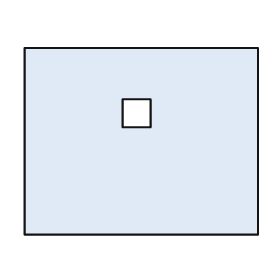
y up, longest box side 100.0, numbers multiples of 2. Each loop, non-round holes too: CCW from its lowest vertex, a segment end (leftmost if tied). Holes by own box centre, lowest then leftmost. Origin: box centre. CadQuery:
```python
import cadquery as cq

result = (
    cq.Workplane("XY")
    .moveTo(-50.0, -40.0)
    .lineTo(50.0, -40.0)
    .lineTo(50.0, 40.0)
    .lineTo(-50.0, 40.0)
    .close()
    .moveTo(-8.0, 6.0)
    .lineTo(4.0, 6.0)
    .lineTo(4.0, 18.0)
    .lineTo(-8.0, 18.0)
    .close()
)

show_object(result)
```